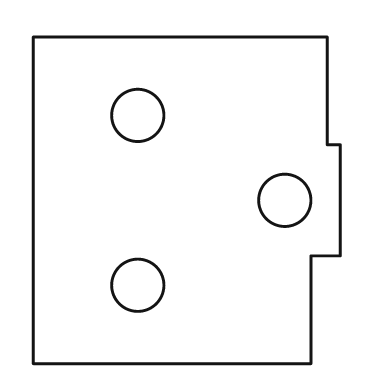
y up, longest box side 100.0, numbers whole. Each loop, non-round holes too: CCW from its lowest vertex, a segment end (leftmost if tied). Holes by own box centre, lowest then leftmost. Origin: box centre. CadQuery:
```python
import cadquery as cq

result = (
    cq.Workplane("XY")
    .moveTo(-47.0, -50.0)
    .lineTo(38.0, -50.0)
    .lineTo(38.0, -17.0)
    .lineTo(47.0, -17.0)
    .lineTo(47.0, 17.0)
    .lineTo(43.0, 17.0)
    .lineTo(43.0, 50.0)
    .lineTo(-47.0, 50.0)
    .close()
    .moveTo(-15.0, -26.0)
    .circle(8.0)
    .moveTo(30.0, 0.0)
    .circle(8.0)
    .moveTo(-15.0, 26.0)
    .circle(8.0)
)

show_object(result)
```